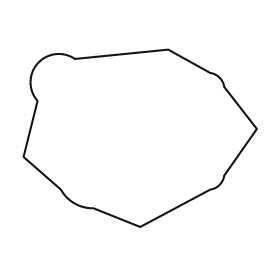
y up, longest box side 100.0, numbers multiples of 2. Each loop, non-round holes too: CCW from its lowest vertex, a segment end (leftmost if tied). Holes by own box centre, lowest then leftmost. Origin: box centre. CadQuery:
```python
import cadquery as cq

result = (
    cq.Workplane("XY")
    .moveTo(0.0, -38.0)
    .lineTo(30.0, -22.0)
    .threePointArc((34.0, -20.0), (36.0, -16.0))
    .lineTo(50.0, 4.0)
    .lineTo(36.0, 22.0)
    .threePointArc((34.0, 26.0), (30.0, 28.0))
    .lineTo(12.0, 38.0)
    .lineTo(-28.0, 34.0)
    .threePointArc((-44.0, 32.0), (-44.0, 16.0))
    .lineTo(-50.0, -8.0)
    .lineTo(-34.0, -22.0)
    .threePointArc((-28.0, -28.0), (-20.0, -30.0))
    .close()
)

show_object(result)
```